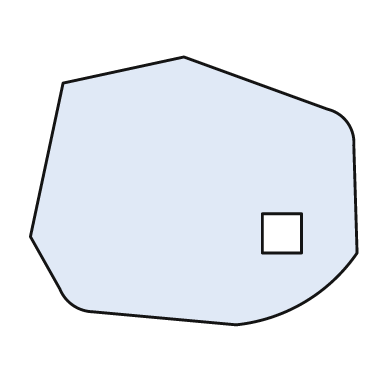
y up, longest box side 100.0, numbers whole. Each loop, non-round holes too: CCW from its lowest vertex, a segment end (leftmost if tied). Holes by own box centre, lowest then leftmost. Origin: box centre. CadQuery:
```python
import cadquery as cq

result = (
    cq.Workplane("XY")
    .moveTo(13.0, -41.0)
    .threePointArc((34.0, -34.0), (50.0, -19.0))
    .lineTo(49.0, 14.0)
    .threePointArc((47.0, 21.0), (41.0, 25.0))
    .lineTo(-3.0, 41.0)
    .lineTo(-40.0, 33.0)
    .lineTo(-50.0, -14.0)
    .lineTo(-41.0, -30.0)
    .threePointArc((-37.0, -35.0), (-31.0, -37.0))
    .close()
    .moveTo(21.0, -19.0)
    .lineTo(33.0, -19.0)
    .lineTo(33.0, -7.0)
    .lineTo(21.0, -7.0)
    .close()
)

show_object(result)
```